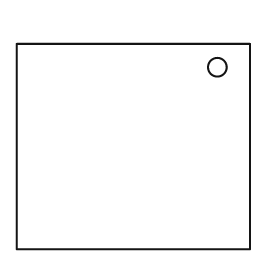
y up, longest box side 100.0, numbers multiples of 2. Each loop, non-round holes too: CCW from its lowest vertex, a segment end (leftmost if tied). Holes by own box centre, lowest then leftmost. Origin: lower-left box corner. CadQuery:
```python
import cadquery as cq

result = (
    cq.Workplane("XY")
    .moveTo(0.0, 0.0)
    .lineTo(100.0, 0.0)
    .lineTo(100.0, 88.0)
    .lineTo(0.0, 88.0)
    .close()
    .moveTo(86.0, 78.0)
    .circle(4.0)
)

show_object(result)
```